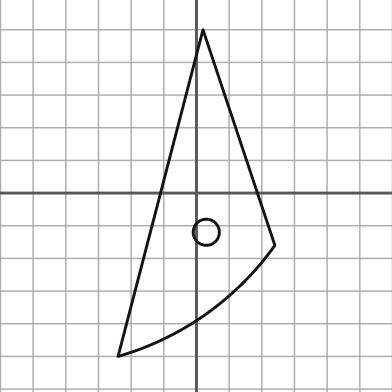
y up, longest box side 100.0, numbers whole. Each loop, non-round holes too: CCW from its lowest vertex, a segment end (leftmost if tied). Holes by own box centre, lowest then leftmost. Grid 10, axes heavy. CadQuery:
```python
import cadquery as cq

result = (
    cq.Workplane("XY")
    .moveTo(-24.0, -50.0)
    .threePointArc((3.0, -37.0), (24.0, -16.0))
    .lineTo(2.0, 50.0)
    .close()
    .moveTo(3.0, -12.0)
    .circle(4.0)
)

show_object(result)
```